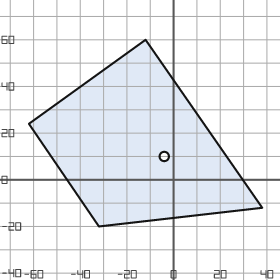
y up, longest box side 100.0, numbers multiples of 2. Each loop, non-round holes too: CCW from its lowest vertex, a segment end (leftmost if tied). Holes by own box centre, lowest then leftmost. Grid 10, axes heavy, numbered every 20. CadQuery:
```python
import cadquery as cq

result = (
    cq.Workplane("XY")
    .moveTo(-32.0, -20.0)
    .lineTo(38.0, -12.0)
    .lineTo(-12.0, 60.0)
    .lineTo(-62.0, 24.0)
    .close()
    .moveTo(-4.0, 10.0)
    .circle(2.0)
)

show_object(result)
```